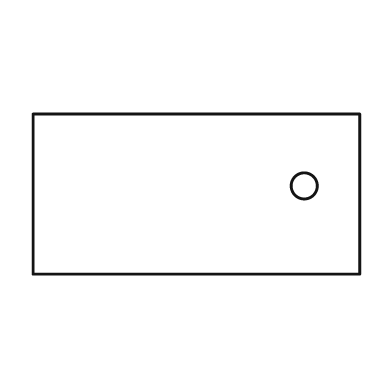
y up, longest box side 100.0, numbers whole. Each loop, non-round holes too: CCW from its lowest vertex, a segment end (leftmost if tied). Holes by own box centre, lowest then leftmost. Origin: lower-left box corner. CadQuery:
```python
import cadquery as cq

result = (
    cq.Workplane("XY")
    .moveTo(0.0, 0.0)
    .lineTo(100.0, 0.0)
    .lineTo(100.0, 49.0)
    .lineTo(0.0, 49.0)
    .close()
    .moveTo(83.0, 27.0)
    .circle(4.0)
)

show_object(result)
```